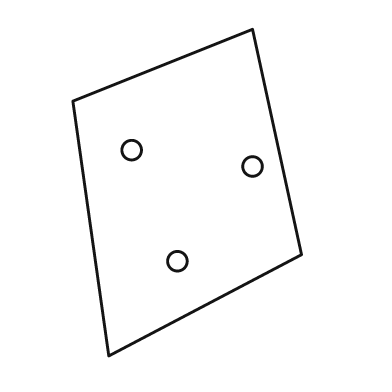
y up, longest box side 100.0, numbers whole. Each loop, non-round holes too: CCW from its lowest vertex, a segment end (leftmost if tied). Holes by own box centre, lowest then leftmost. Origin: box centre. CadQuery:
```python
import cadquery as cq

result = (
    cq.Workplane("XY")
    .moveTo(-24.0, -50.0)
    .lineTo(35.0, -19.0)
    .lineTo(20.0, 50.0)
    .lineTo(-35.0, 28.0)
    .close()
    .moveTo(-3.0, -21.0)
    .circle(3.0)
    .moveTo(20.0, 8.0)
    .circle(3.0)
    .moveTo(-17.0, 13.0)
    .circle(3.0)
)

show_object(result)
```